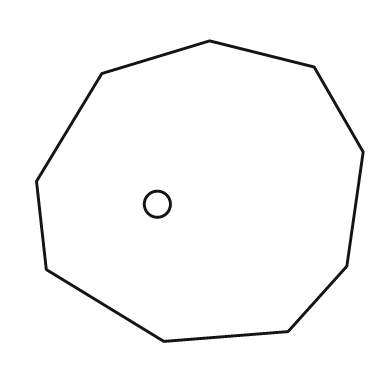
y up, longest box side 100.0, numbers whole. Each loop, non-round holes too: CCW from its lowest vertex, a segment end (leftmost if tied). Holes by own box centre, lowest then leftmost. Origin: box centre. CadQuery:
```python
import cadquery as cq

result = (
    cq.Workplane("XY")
    .moveTo(-11.0, -46.0)
    .lineTo(27.0, -43.0)
    .lineTo(45.0, -23.0)
    .lineTo(50.0, 12.0)
    .lineTo(35.0, 38.0)
    .lineTo(3.0, 46.0)
    .lineTo(-30.0, 36.0)
    .lineTo(-50.0, 3.0)
    .lineTo(-47.0, -24.0)
    .close()
    .moveTo(-13.0, -4.0)
    .circle(4.0)
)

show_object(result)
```